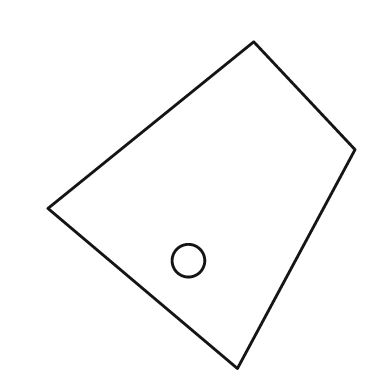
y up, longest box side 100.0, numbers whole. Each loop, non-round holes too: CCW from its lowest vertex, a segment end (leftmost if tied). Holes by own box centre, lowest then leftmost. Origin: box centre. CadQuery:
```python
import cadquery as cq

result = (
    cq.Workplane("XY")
    .moveTo(11.0, -50.0)
    .lineTo(47.0, 17.0)
    .lineTo(16.0, 50.0)
    .lineTo(-47.0, -1.0)
    .close()
    .moveTo(-4.0, -17.0)
    .circle(5.0)
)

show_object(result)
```